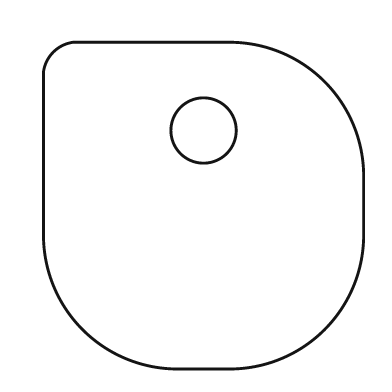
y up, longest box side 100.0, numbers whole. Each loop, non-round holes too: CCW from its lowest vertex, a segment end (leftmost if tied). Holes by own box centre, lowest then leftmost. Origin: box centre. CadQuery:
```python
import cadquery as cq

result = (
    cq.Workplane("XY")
    .moveTo(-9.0, -50.0)
    .lineTo(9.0, -50.0)
    .threePointArc((37.0, -38.0), (49.0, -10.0))
    .lineTo(49.0, 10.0)
    .threePointArc((37.0, 38.0), (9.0, 50.0))
    .lineTo(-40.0, 50.0)
    .threePointArc((-46.0, 47.0), (-49.0, 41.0))
    .lineTo(-49.0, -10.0)
    .threePointArc((-37.0, -38.0), (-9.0, -50.0))
    .close()
    .moveTo(0.0, 23.0)
    .circle(10.0)
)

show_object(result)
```